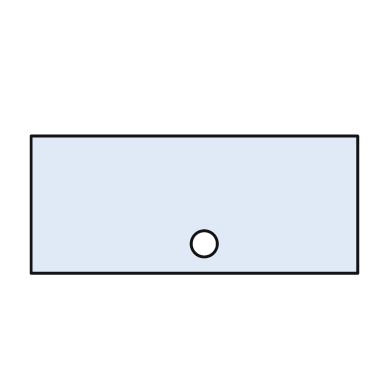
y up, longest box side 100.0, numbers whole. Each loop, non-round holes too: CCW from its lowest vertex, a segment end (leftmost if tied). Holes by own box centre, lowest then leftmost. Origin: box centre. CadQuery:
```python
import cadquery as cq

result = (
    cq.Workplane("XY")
    .moveTo(-50.0, -21.0)
    .lineTo(50.0, -21.0)
    .lineTo(50.0, 21.0)
    .lineTo(-50.0, 21.0)
    .close()
    .moveTo(3.0, -12.0)
    .circle(4.0)
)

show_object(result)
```